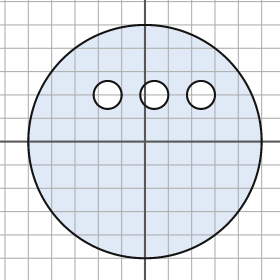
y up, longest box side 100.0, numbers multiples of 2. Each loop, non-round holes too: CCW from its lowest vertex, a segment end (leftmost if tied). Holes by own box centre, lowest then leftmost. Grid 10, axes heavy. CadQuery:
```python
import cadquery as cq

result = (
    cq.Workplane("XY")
    .moveTo(0.0, 0.0)
    .circle(50.0)
    .moveTo(-16.0, 20.0)
    .circle(6.0)
    .moveTo(4.0, 20.0)
    .circle(6.0)
    .moveTo(24.0, 20.0)
    .circle(6.0)
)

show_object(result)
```